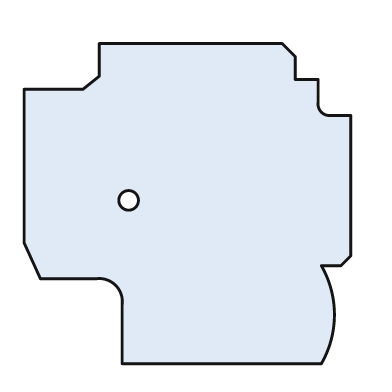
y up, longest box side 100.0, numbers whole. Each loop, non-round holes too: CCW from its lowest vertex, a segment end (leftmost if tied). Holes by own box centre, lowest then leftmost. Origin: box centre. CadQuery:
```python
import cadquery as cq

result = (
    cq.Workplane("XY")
    .moveTo(-20.0, -49.0)
    .lineTo(41.0, -49.0)
    .threePointArc((45.0, -34.0), (41.0, -19.0))
    .lineTo(47.0, -19.0)
    .lineTo(50.0, -16.0)
    .lineTo(50.0, 27.0)
    .lineTo(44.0, 27.0)
    .threePointArc((41.0, 28.0), (40.0, 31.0))
    .lineTo(40.0, 38.0)
    .lineTo(33.0, 38.0)
    .lineTo(33.0, 45.0)
    .lineTo(29.0, 49.0)
    .lineTo(-27.0, 49.0)
    .lineTo(-27.0, 39.0)
    .lineTo(-32.0, 35.0)
    .lineTo(-50.0, 35.0)
    .lineTo(-50.0, -12.0)
    .lineTo(-45.0, -23.0)
    .lineTo(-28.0, -23.0)
    .threePointArc((-22.0, -25.0), (-20.0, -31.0))
    .close()
    .moveTo(-18.0, 1.0)
    .circle(3.0)
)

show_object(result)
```